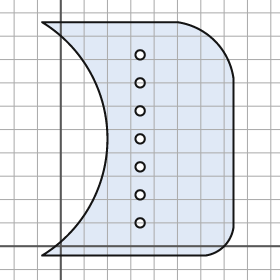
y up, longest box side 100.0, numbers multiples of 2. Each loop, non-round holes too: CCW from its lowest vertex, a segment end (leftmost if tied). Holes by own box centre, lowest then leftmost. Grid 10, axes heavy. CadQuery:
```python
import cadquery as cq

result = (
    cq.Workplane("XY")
    .moveTo(-8.0, -4.0)
    .lineTo(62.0, -4.0)
    .threePointArc((70.0, 0.0), (74.0, 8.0))
    .lineTo(74.0, 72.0)
    .threePointArc((66.0, 88.0), (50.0, 96.0))
    .lineTo(-8.0, 96.0)
    .threePointArc((20.0, 46.0), (-8.0, -4.0))
    .close()
    .moveTo(34.0, 10.0)
    .circle(2.0)
    .moveTo(34.0, 22.0)
    .circle(2.0)
    .moveTo(34.0, 34.0)
    .circle(2.0)
    .moveTo(34.0, 46.0)
    .circle(2.0)
    .moveTo(34.0, 58.0)
    .circle(2.0)
    .moveTo(34.0, 70.0)
    .circle(2.0)
    .moveTo(34.0, 82.0)
    .circle(2.0)
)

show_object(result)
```